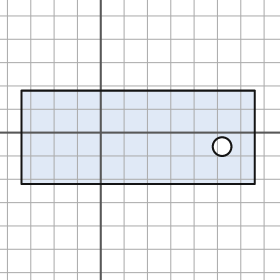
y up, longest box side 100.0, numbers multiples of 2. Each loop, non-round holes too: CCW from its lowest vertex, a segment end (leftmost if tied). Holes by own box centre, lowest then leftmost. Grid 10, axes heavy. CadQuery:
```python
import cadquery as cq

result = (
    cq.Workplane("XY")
    .moveTo(-34.0, -22.0)
    .lineTo(66.0, -22.0)
    .lineTo(66.0, 18.0)
    .lineTo(-34.0, 18.0)
    .close()
    .moveTo(52.0, -6.0)
    .circle(4.0)
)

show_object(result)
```